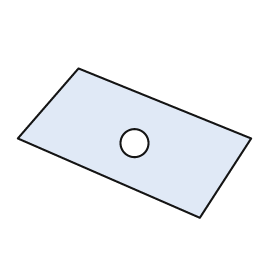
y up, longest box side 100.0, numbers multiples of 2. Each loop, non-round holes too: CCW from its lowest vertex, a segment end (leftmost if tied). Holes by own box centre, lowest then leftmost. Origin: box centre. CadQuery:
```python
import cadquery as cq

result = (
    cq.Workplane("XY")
    .moveTo(28.0, -32.0)
    .lineTo(50.0, 2.0)
    .lineTo(-24.0, 32.0)
    .lineTo(-50.0, 2.0)
    .close()
    .moveTo(0.0, 0.0)
    .circle(6.0)
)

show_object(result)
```